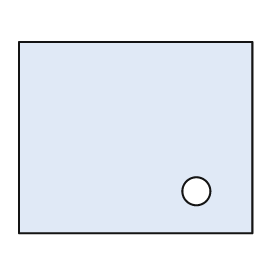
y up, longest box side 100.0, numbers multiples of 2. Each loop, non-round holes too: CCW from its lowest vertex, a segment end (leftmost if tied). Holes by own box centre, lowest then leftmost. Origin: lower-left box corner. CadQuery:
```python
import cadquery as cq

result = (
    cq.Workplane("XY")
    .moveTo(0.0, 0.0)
    .lineTo(100.0, 0.0)
    .lineTo(100.0, 82.0)
    .lineTo(0.0, 82.0)
    .close()
    .moveTo(76.0, 18.0)
    .circle(6.0)
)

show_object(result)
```